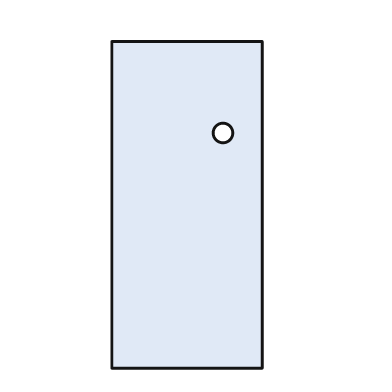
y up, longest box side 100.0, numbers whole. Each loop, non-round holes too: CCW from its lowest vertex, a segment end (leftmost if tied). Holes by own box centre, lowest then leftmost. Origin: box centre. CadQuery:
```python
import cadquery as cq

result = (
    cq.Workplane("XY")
    .moveTo(-23.0, -50.0)
    .lineTo(23.0, -50.0)
    .lineTo(23.0, 50.0)
    .lineTo(-23.0, 50.0)
    .close()
    .moveTo(11.0, 22.0)
    .circle(3.0)
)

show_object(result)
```